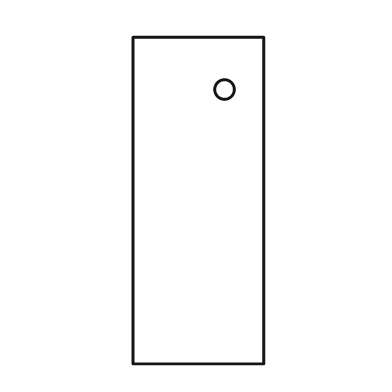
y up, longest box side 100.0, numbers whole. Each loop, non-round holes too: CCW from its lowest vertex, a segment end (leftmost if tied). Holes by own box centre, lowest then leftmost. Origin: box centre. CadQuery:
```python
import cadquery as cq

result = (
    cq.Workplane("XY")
    .moveTo(-20.0, -50.0)
    .lineTo(20.0, -50.0)
    .lineTo(20.0, 50.0)
    .lineTo(-20.0, 50.0)
    .close()
    .moveTo(8.0, 34.0)
    .circle(3.0)
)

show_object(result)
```